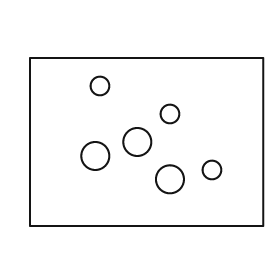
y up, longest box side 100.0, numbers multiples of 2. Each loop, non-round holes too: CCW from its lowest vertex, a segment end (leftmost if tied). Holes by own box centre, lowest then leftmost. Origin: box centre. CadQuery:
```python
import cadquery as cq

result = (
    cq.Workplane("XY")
    .moveTo(-50.0, -36.0)
    .lineTo(50.0, -36.0)
    .lineTo(50.0, 36.0)
    .lineTo(-50.0, 36.0)
    .close()
    .moveTo(10.0, -16.0)
    .circle(6.0)
    .moveTo(28.0, -12.0)
    .circle(4.0)
    .moveTo(-22.0, -6.0)
    .circle(6.0)
    .moveTo(-4.0, 0.0)
    .circle(6.0)
    .moveTo(10.0, 12.0)
    .circle(4.0)
    .moveTo(-20.0, 24.0)
    .circle(4.0)
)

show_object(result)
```